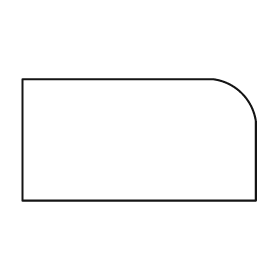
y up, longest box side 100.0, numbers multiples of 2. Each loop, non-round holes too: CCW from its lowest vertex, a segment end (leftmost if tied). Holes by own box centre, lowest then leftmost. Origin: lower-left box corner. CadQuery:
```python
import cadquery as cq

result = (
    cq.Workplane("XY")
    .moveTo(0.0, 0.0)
    .lineTo(100.0, 0.0)
    .lineTo(100.0, 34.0)
    .threePointArc((94.0, 46.0), (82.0, 52.0))
    .lineTo(0.0, 52.0)
    .close()
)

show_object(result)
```